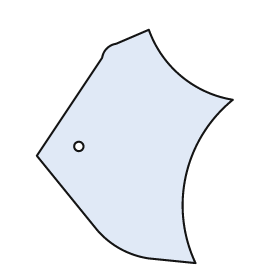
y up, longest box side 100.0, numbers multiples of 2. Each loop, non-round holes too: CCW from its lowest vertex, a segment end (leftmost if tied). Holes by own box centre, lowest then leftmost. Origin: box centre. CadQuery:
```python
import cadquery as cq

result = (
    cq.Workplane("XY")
    .moveTo(26.0, -50.0)
    .threePointArc((22.0, -12.0), (42.0, 20.0))
    .threePointArc((20.0, 30.0), (6.0, 50.0))
    .lineTo(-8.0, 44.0)
    .threePointArc((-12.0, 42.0), (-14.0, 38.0))
    .lineTo(-42.0, -4.0)
    .lineTo(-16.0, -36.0)
    .threePointArc((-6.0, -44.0), (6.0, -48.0))
    .close()
    .moveTo(-24.0, 0.0)
    .circle(2.0)
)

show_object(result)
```